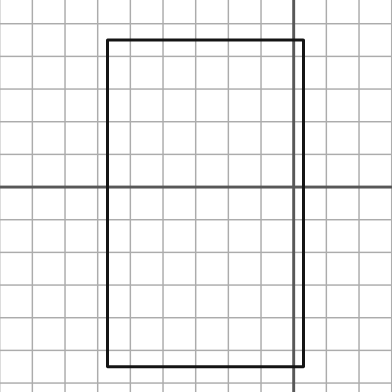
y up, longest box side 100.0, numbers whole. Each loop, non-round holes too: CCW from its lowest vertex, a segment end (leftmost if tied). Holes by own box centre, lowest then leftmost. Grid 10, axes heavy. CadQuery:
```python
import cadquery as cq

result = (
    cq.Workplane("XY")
    .moveTo(-57.0, -55.0)
    .lineTo(3.0, -55.0)
    .lineTo(3.0, 45.0)
    .lineTo(-57.0, 45.0)
    .close()
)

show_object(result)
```